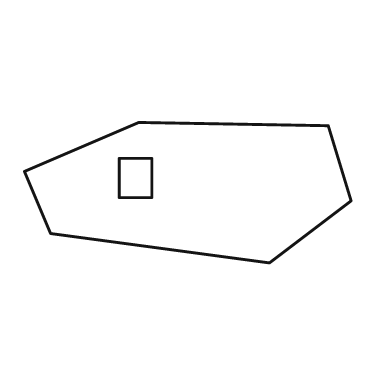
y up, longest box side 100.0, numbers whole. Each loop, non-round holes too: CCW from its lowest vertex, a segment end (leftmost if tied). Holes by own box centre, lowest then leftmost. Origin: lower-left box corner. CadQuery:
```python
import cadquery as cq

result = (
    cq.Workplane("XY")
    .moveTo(75.0, 0.0)
    .lineTo(100.0, 19.0)
    .lineTo(93.0, 42.0)
    .lineTo(35.0, 43.0)
    .lineTo(0.0, 28.0)
    .lineTo(8.0, 9.0)
    .close()
    .moveTo(29.0, 20.0)
    .lineTo(39.0, 20.0)
    .lineTo(39.0, 32.0)
    .lineTo(29.0, 32.0)
    .close()
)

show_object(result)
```